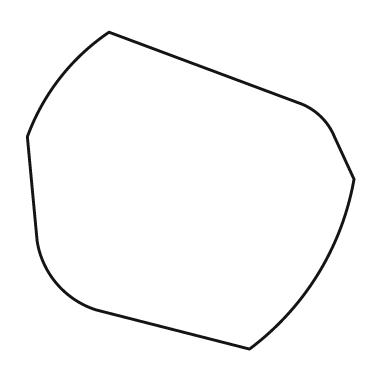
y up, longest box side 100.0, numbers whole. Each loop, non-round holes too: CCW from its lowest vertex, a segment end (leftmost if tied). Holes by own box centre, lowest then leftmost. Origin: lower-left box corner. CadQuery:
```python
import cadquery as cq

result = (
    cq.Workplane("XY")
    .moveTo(68.0, 0.0)
    .threePointArc((89.0, 23.0), (100.0, 52.0))
    .lineTo(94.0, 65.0)
    .threePointArc((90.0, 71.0), (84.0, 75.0))
    .lineTo(25.0, 97.0)
    .threePointArc((10.0, 83.0), (0.0, 65.0))
    .lineTo(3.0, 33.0)
    .threePointArc((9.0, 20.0), (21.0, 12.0))
    .close()
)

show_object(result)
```